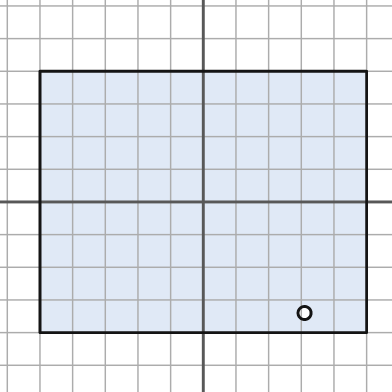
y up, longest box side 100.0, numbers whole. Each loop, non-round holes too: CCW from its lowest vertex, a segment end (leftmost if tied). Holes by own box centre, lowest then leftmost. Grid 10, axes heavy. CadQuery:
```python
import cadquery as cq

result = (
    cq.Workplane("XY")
    .moveTo(-50.0, -40.0)
    .lineTo(50.0, -40.0)
    .lineTo(50.0, 40.0)
    .lineTo(-50.0, 40.0)
    .close()
    .moveTo(31.0, -34.0)
    .circle(2.0)
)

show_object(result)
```